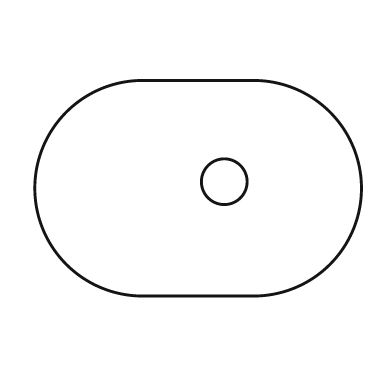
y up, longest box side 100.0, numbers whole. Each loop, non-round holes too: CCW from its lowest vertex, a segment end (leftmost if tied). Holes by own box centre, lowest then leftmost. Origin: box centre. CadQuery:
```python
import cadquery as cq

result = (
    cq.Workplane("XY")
    .moveTo(-17.0, -33.0)
    .lineTo(17.0, -33.0)
    .threePointArc((50.0, 0.0), (17.0, 33.0))
    .lineTo(-17.0, 33.0)
    .threePointArc((-50.0, 0.0), (-17.0, -33.0))
    .close()
    .moveTo(8.0, 2.0)
    .circle(7.0)
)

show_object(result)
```